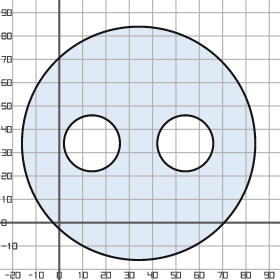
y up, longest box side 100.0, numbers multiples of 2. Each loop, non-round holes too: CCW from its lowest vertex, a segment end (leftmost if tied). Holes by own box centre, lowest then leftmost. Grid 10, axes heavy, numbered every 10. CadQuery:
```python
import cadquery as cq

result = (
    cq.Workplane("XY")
    .moveTo(34.0, 34.0)
    .circle(50.0)
    .moveTo(14.0, 34.0)
    .circle(12.0)
    .moveTo(54.0, 34.0)
    .circle(12.0)
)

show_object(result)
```